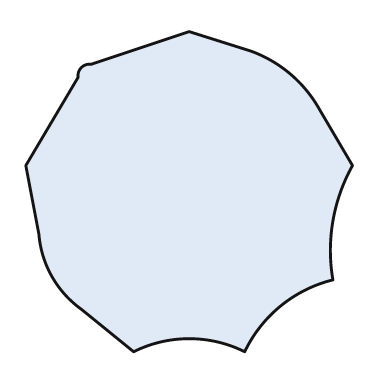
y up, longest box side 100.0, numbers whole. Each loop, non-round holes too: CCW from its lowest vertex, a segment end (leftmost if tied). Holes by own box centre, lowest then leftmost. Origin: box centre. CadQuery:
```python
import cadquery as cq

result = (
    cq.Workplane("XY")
    .moveTo(-17.0, -49.0)
    .threePointArc((0.0, -45.0), (17.0, -49.0))
    .threePointArc((28.0, -35.0), (44.0, -27.0))
    .threePointArc((44.0, -9.0), (50.0, 8.0))
    .lineTo(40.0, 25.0)
    .threePointArc((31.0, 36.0), (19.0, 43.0))
    .lineTo(0.0, 49.0)
    .lineTo(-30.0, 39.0)
    .threePointArc((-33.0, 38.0), (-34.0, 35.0))
    .lineTo(-50.0, 8.0)
    .lineTo(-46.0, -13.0)
    .threePointArc((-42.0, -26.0), (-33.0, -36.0))
    .close()
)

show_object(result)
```